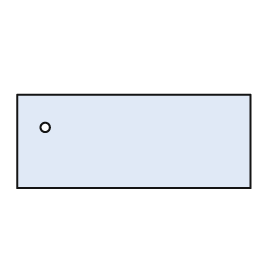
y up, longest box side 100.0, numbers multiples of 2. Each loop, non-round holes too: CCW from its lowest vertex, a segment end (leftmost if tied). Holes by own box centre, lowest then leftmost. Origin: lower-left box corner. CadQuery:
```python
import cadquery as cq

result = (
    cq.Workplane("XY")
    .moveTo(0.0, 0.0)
    .lineTo(100.0, 0.0)
    .lineTo(100.0, 40.0)
    .lineTo(0.0, 40.0)
    .close()
    .moveTo(12.0, 26.0)
    .circle(2.0)
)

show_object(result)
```